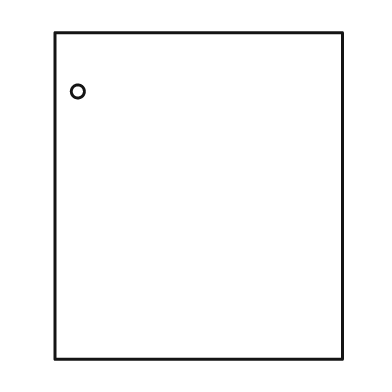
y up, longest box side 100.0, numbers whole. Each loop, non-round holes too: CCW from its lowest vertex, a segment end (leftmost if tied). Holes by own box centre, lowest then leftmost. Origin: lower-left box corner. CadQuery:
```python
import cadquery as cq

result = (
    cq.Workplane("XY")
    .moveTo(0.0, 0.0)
    .lineTo(88.0, 0.0)
    .lineTo(88.0, 100.0)
    .lineTo(0.0, 100.0)
    .close()
    .moveTo(7.0, 82.0)
    .circle(2.0)
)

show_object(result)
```